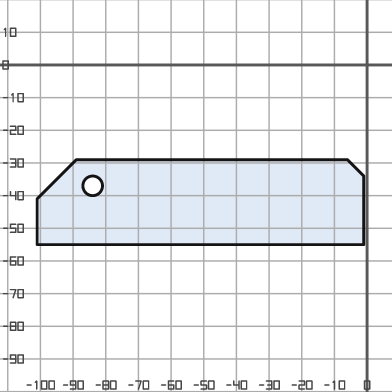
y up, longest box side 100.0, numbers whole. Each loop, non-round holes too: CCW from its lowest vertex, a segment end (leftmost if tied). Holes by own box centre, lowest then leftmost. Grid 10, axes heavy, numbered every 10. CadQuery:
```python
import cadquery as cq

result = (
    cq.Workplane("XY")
    .moveTo(-101.0, -55.0)
    .lineTo(-1.0, -55.0)
    .lineTo(-1.0, -34.0)
    .lineTo(-6.0, -29.0)
    .lineTo(-89.0, -29.0)
    .lineTo(-101.0, -41.0)
    .close()
    .moveTo(-84.0, -37.0)
    .circle(3.0)
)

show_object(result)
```